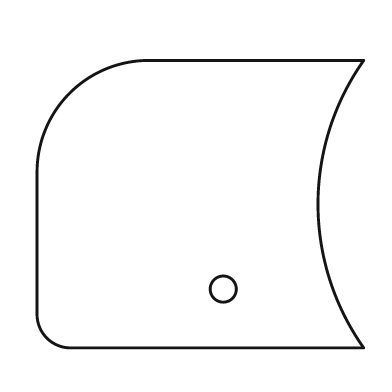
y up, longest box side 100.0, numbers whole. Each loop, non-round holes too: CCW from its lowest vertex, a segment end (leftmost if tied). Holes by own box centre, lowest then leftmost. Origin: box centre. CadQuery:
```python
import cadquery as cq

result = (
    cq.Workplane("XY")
    .moveTo(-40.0, -44.0)
    .lineTo(50.0, -44.0)
    .threePointArc((36.0, 0.0), (50.0, 44.0))
    .lineTo(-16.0, 44.0)
    .threePointArc((-40.0, 34.0), (-50.0, 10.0))
    .lineTo(-50.0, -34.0)
    .threePointArc((-47.0, -41.0), (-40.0, -44.0))
    .close()
    .moveTo(7.0, -26.0)
    .circle(4.0)
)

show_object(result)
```